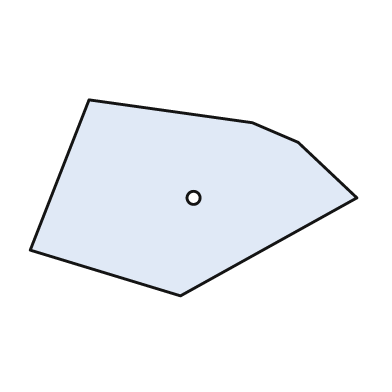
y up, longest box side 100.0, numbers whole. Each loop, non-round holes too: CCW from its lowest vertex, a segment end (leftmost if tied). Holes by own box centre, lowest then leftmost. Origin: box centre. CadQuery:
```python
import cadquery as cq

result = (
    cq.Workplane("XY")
    .moveTo(-4.0, -30.0)
    .lineTo(50.0, 0.0)
    .lineTo(32.0, 17.0)
    .lineTo(18.0, 23.0)
    .lineTo(-32.0, 30.0)
    .lineTo(-50.0, -16.0)
    .close()
    .moveTo(0.0, 0.0)
    .circle(2.0)
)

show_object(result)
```